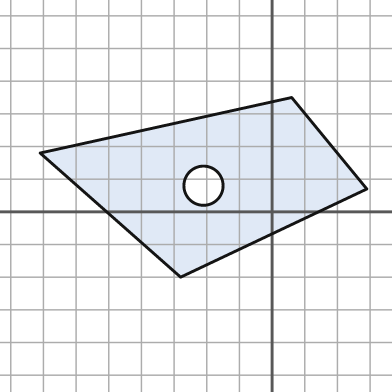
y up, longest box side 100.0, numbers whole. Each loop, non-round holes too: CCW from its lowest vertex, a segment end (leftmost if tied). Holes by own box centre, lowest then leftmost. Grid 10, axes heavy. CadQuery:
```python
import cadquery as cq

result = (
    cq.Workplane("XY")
    .moveTo(-28.0, -20.0)
    .lineTo(29.0, 7.0)
    .lineTo(6.0, 35.0)
    .lineTo(-71.0, 18.0)
    .close()
    .moveTo(-21.0, 8.0)
    .circle(6.0)
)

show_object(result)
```